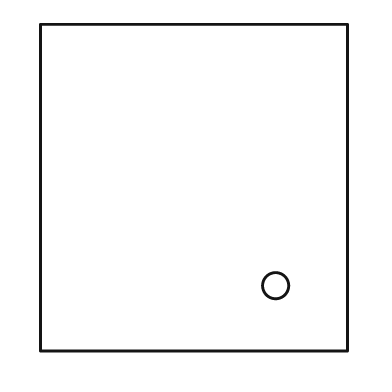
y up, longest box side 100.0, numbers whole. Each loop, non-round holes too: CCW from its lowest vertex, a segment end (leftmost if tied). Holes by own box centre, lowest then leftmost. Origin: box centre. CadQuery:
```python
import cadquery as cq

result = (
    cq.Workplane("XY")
    .moveTo(-47.0, -50.0)
    .lineTo(47.0, -50.0)
    .lineTo(47.0, 50.0)
    .lineTo(-47.0, 50.0)
    .close()
    .moveTo(25.0, -30.0)
    .circle(4.0)
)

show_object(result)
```